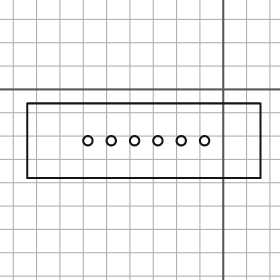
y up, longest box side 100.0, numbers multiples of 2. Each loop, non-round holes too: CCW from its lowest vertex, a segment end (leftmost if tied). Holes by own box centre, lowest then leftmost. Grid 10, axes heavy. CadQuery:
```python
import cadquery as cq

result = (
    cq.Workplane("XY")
    .moveTo(-84.0, -38.0)
    .lineTo(16.0, -38.0)
    .lineTo(16.0, -6.0)
    .lineTo(-84.0, -6.0)
    .close()
    .moveTo(-58.0, -22.0)
    .circle(2.0)
    .moveTo(-48.0, -22.0)
    .circle(2.0)
    .moveTo(-38.0, -22.0)
    .circle(2.0)
    .moveTo(-28.0, -22.0)
    .circle(2.0)
    .moveTo(-18.0, -22.0)
    .circle(2.0)
    .moveTo(-8.0, -22.0)
    .circle(2.0)
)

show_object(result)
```